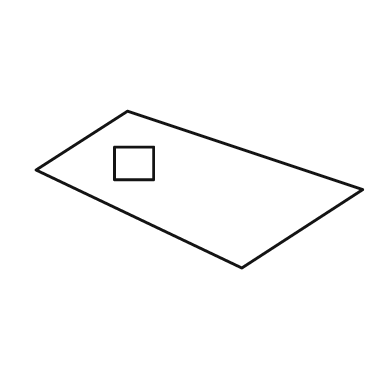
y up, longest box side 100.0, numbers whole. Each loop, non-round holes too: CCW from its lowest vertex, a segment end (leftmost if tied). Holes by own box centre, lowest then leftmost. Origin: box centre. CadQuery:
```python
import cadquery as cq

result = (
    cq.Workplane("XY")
    .moveTo(13.0, -24.0)
    .lineTo(50.0, 0.0)
    .lineTo(-22.0, 24.0)
    .lineTo(-50.0, 6.0)
    .close()
    .moveTo(-26.0, 3.0)
    .lineTo(-14.0, 3.0)
    .lineTo(-14.0, 13.0)
    .lineTo(-26.0, 13.0)
    .close()
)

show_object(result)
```